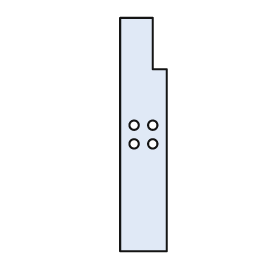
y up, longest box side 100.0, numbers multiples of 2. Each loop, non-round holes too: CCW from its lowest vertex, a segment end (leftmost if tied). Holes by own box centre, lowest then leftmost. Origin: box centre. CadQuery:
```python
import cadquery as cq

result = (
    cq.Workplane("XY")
    .moveTo(-10.0, -50.0)
    .lineTo(10.0, -50.0)
    .lineTo(10.0, 28.0)
    .lineTo(4.0, 28.0)
    .lineTo(4.0, 50.0)
    .lineTo(-10.0, 50.0)
    .close()
    .moveTo(-4.0, -4.0)
    .circle(2.0)
    .moveTo(4.0, -4.0)
    .circle(2.0)
    .moveTo(-4.0, 4.0)
    .circle(2.0)
    .moveTo(4.0, 4.0)
    .circle(2.0)
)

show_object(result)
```